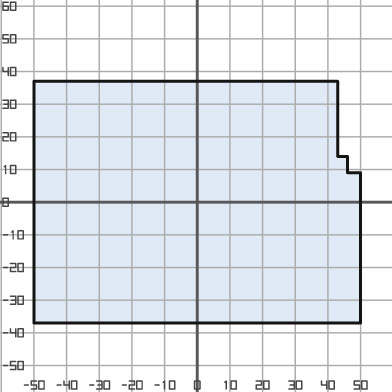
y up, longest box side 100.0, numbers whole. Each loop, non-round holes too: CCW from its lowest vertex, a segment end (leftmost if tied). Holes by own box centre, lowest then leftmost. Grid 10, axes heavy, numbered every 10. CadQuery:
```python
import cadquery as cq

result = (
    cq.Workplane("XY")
    .moveTo(-50.0, -37.0)
    .lineTo(50.0, -37.0)
    .lineTo(50.0, 9.0)
    .lineTo(46.0, 9.0)
    .lineTo(46.0, 14.0)
    .lineTo(43.0, 14.0)
    .lineTo(43.0, 37.0)
    .lineTo(-50.0, 37.0)
    .close()
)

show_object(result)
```